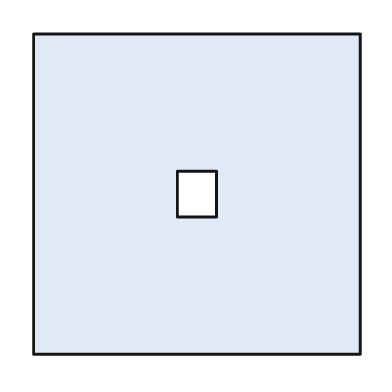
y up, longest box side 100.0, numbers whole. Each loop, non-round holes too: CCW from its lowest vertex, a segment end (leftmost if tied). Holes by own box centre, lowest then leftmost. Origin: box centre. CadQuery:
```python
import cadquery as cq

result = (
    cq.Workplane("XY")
    .moveTo(-50.0, -49.0)
    .lineTo(50.0, -49.0)
    .lineTo(50.0, 49.0)
    .lineTo(-50.0, 49.0)
    .close()
    .moveTo(-6.0, -7.0)
    .lineTo(6.0, -7.0)
    .lineTo(6.0, 7.0)
    .lineTo(-6.0, 7.0)
    .close()
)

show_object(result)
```